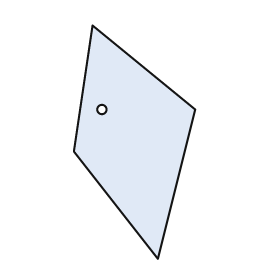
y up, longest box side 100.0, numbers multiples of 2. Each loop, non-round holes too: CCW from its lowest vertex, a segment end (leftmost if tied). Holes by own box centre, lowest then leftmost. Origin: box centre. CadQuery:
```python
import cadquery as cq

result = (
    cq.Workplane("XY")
    .moveTo(10.0, -50.0)
    .lineTo(26.0, 14.0)
    .lineTo(-18.0, 50.0)
    .lineTo(-26.0, -4.0)
    .close()
    .moveTo(-14.0, 14.0)
    .circle(2.0)
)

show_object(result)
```